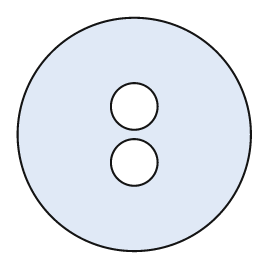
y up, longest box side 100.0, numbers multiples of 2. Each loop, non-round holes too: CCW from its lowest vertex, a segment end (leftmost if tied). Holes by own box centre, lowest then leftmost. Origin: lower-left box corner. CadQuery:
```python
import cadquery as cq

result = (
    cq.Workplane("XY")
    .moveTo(50.0, 50.0)
    .circle(50.0)
    .moveTo(50.0, 38.0)
    .circle(10.0)
    .moveTo(50.0, 62.0)
    .circle(10.0)
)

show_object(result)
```